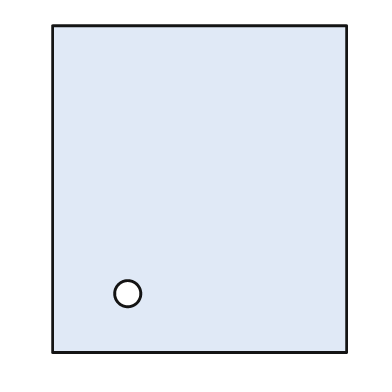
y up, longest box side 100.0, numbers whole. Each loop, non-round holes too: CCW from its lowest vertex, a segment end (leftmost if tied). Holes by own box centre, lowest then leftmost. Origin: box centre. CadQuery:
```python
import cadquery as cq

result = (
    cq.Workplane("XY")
    .moveTo(-45.0, -50.0)
    .lineTo(45.0, -50.0)
    .lineTo(45.0, 50.0)
    .lineTo(-45.0, 50.0)
    .close()
    .moveTo(-22.0, -32.0)
    .circle(4.0)
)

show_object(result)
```